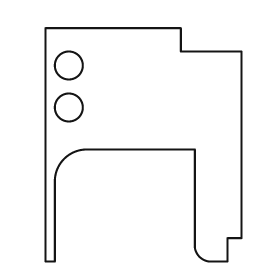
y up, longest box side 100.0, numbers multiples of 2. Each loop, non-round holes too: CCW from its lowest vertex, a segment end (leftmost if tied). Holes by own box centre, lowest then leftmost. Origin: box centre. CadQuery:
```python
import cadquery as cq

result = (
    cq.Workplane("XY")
    .moveTo(-42.0, -50.0)
    .lineTo(-38.0, -50.0)
    .lineTo(-38.0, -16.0)
    .threePointArc((-34.0, -6.0), (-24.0, -2.0))
    .lineTo(22.0, -2.0)
    .lineTo(22.0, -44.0)
    .threePointArc((24.0, -48.0), (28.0, -50.0))
    .lineTo(36.0, -50.0)
    .lineTo(36.0, -40.0)
    .lineTo(42.0, -40.0)
    .lineTo(42.0, 40.0)
    .lineTo(16.0, 40.0)
    .lineTo(16.0, 50.0)
    .lineTo(-42.0, 50.0)
    .close()
    .moveTo(-32.0, 16.0)
    .circle(6.0)
    .moveTo(-32.0, 34.0)
    .circle(6.0)
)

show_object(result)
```